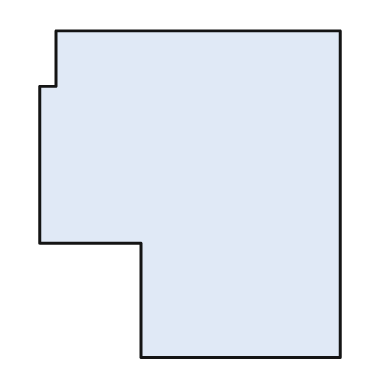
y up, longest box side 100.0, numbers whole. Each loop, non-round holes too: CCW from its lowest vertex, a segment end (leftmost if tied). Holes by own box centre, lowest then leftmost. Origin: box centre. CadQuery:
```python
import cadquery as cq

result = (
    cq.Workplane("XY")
    .moveTo(-15.0, -50.0)
    .lineTo(46.0, -50.0)
    .lineTo(46.0, 50.0)
    .lineTo(-41.0, 50.0)
    .lineTo(-41.0, 33.0)
    .lineTo(-46.0, 33.0)
    .lineTo(-46.0, -15.0)
    .lineTo(-15.0, -15.0)
    .close()
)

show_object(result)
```